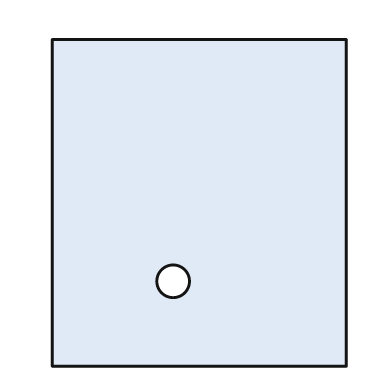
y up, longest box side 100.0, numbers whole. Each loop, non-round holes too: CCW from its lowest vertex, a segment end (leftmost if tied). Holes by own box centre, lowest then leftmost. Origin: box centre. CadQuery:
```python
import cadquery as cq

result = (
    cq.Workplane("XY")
    .moveTo(-45.0, -50.0)
    .lineTo(45.0, -50.0)
    .lineTo(45.0, 50.0)
    .lineTo(-45.0, 50.0)
    .close()
    .moveTo(-8.0, -24.0)
    .circle(5.0)
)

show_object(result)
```